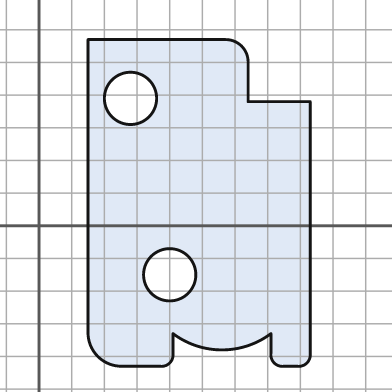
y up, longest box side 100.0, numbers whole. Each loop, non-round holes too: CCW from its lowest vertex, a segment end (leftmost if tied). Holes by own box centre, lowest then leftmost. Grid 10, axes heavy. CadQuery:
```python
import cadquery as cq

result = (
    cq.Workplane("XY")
    .moveTo(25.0, -43.0)
    .lineTo(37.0, -43.0)
    .threePointArc((40.0, -42.0), (41.0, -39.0))
    .lineTo(41.0, -33.0)
    .threePointArc((56.0, -38.0), (71.0, -33.0))
    .lineTo(71.0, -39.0)
    .threePointArc((72.0, -42.0), (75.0, -43.0))
    .lineTo(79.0, -43.0)
    .threePointArc((82.0, -42.0), (83.0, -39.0))
    .lineTo(83.0, 38.0)
    .lineTo(64.0, 38.0)
    .lineTo(64.0, 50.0)
    .threePointArc((62.0, 55.0), (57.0, 57.0))
    .lineTo(15.0, 57.0)
    .lineTo(15.0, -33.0)
    .threePointArc((18.0, -40.0), (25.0, -43.0))
    .close()
    .moveTo(40.0, -15.0)
    .circle(8.0)
    .moveTo(28.0, 39.0)
    .circle(8.0)
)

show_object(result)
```